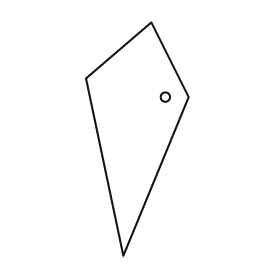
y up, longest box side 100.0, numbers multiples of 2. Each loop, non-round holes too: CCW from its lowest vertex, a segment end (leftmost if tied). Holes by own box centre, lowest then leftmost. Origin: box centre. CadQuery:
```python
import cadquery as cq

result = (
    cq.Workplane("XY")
    .moveTo(-6.0, -50.0)
    .lineTo(22.0, 18.0)
    .lineTo(6.0, 50.0)
    .lineTo(-22.0, 26.0)
    .close()
    .moveTo(12.0, 18.0)
    .circle(2.0)
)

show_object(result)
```